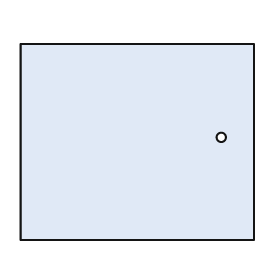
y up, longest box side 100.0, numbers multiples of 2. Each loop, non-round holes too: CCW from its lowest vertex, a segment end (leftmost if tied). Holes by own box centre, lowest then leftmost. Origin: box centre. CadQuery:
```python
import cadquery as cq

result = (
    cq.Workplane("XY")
    .moveTo(-50.0, -42.0)
    .lineTo(50.0, -42.0)
    .lineTo(50.0, 42.0)
    .lineTo(-50.0, 42.0)
    .close()
    .moveTo(36.0, 2.0)
    .circle(2.0)
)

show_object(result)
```